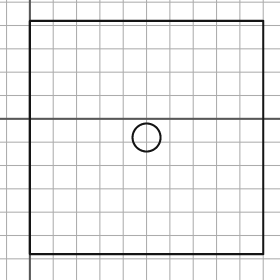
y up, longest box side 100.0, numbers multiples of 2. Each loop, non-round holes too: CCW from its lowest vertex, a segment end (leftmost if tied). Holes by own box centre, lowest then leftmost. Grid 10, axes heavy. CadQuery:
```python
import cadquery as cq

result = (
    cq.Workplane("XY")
    .moveTo(0.0, -58.0)
    .lineTo(100.0, -58.0)
    .lineTo(100.0, 42.0)
    .lineTo(0.0, 42.0)
    .close()
    .moveTo(50.0, -8.0)
    .circle(6.0)
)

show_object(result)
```